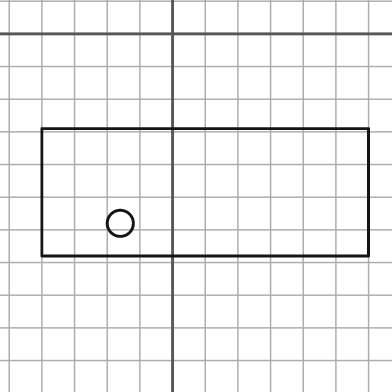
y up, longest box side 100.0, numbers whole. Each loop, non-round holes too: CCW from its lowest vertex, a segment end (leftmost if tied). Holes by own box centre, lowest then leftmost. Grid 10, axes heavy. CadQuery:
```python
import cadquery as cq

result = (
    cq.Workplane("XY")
    .moveTo(-40.0, -68.0)
    .lineTo(60.0, -68.0)
    .lineTo(60.0, -29.0)
    .lineTo(-40.0, -29.0)
    .close()
    .moveTo(-16.0, -58.0)
    .circle(4.0)
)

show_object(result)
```